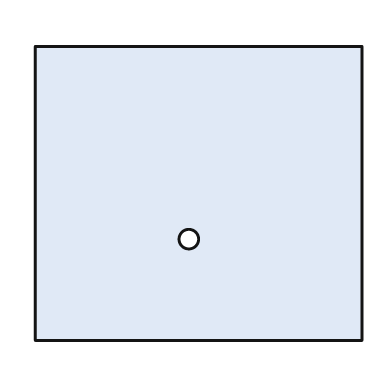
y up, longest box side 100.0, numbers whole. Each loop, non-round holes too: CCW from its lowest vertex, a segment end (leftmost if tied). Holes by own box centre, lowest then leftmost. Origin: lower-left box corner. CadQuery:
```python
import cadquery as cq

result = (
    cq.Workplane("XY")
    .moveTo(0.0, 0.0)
    .lineTo(100.0, 0.0)
    .lineTo(100.0, 90.0)
    .lineTo(0.0, 90.0)
    .close()
    .moveTo(47.0, 31.0)
    .circle(3.0)
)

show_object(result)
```